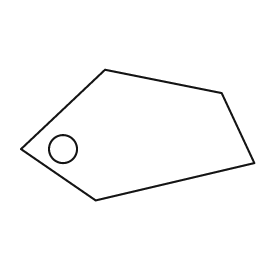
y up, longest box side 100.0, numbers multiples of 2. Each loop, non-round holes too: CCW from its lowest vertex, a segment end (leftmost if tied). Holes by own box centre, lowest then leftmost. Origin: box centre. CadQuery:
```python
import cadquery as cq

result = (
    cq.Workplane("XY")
    .moveTo(-18.0, -28.0)
    .lineTo(50.0, -12.0)
    .lineTo(36.0, 18.0)
    .lineTo(-14.0, 28.0)
    .lineTo(-50.0, -6.0)
    .close()
    .moveTo(-32.0, -6.0)
    .circle(6.0)
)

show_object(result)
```